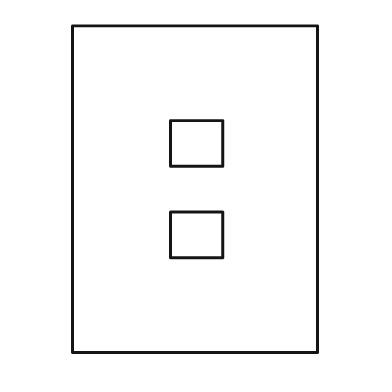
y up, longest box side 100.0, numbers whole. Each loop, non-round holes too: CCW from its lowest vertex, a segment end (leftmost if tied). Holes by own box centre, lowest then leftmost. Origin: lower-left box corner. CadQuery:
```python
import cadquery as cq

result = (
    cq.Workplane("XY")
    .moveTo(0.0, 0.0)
    .lineTo(75.0, 0.0)
    .lineTo(75.0, 100.0)
    .lineTo(0.0, 100.0)
    .close()
    .moveTo(30.0, 29.0)
    .lineTo(46.0, 29.0)
    .lineTo(46.0, 43.0)
    .lineTo(30.0, 43.0)
    .close()
    .moveTo(30.0, 57.0)
    .lineTo(46.0, 57.0)
    .lineTo(46.0, 71.0)
    .lineTo(30.0, 71.0)
    .close()
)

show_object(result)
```